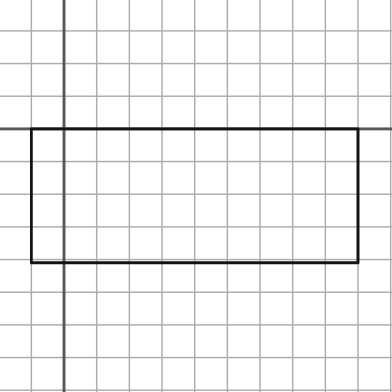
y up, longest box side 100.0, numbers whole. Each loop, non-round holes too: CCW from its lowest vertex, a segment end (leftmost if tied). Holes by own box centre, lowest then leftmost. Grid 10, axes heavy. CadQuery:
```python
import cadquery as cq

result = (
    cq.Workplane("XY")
    .moveTo(-10.0, -41.0)
    .lineTo(90.0, -41.0)
    .lineTo(90.0, 0.0)
    .lineTo(-10.0, 0.0)
    .close()
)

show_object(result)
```